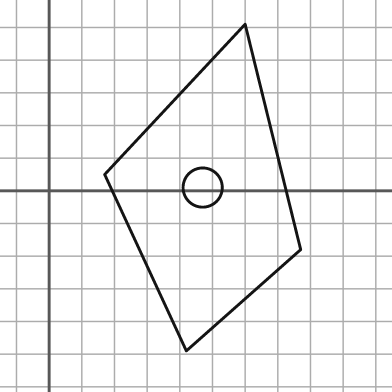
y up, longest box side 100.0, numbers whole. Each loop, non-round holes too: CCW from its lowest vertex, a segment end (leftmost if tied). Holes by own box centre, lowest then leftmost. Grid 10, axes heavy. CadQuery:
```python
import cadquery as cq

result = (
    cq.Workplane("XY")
    .moveTo(42.0, -49.0)
    .lineTo(77.0, -18.0)
    .lineTo(60.0, 51.0)
    .lineTo(17.0, 5.0)
    .close()
    .moveTo(47.0, 1.0)
    .circle(6.0)
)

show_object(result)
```